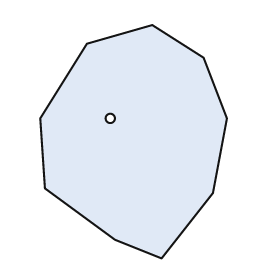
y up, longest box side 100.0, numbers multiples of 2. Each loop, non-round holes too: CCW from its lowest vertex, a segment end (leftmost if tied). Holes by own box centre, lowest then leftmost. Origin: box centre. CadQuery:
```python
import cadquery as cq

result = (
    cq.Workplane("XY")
    .moveTo(12.0, -50.0)
    .lineTo(34.0, -22.0)
    .lineTo(40.0, 10.0)
    .lineTo(30.0, 36.0)
    .lineTo(8.0, 50.0)
    .lineTo(-20.0, 42.0)
    .lineTo(-40.0, 10.0)
    .lineTo(-38.0, -20.0)
    .lineTo(-8.0, -42.0)
    .close()
    .moveTo(-10.0, 10.0)
    .circle(2.0)
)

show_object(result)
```